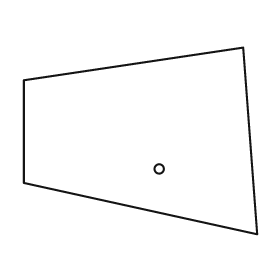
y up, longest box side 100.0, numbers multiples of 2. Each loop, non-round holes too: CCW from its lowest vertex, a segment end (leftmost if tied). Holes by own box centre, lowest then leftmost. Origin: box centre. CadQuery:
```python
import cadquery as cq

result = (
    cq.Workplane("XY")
    .moveTo(50.0, -40.0)
    .lineTo(44.0, 40.0)
    .lineTo(-50.0, 26.0)
    .lineTo(-50.0, -18.0)
    .close()
    .moveTo(8.0, -12.0)
    .circle(2.0)
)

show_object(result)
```